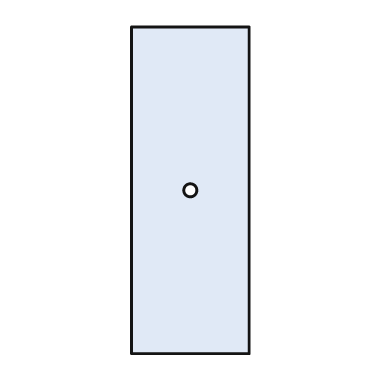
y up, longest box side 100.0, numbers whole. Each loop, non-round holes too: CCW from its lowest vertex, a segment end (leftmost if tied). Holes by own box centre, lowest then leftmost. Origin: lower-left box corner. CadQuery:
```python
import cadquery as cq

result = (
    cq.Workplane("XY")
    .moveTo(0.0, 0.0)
    .lineTo(36.0, 0.0)
    .lineTo(36.0, 100.0)
    .lineTo(0.0, 100.0)
    .close()
    .moveTo(18.0, 50.0)
    .circle(2.0)
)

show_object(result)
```